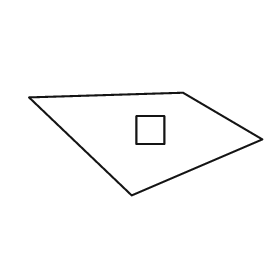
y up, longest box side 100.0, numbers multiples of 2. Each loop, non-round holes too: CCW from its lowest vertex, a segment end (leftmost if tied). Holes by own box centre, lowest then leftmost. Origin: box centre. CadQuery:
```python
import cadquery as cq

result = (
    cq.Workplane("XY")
    .moveTo(-6.0, -22.0)
    .lineTo(50.0, 2.0)
    .lineTo(16.0, 22.0)
    .lineTo(-50.0, 20.0)
    .close()
    .moveTo(-4.0, 0.0)
    .lineTo(8.0, 0.0)
    .lineTo(8.0, 12.0)
    .lineTo(-4.0, 12.0)
    .close()
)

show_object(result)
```